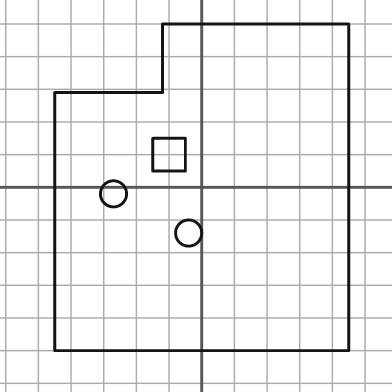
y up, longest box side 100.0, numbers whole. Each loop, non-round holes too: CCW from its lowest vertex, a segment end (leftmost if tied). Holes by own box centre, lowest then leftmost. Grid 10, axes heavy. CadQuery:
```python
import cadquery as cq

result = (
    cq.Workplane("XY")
    .moveTo(-45.0, -50.0)
    .lineTo(45.0, -50.0)
    .lineTo(45.0, 50.0)
    .lineTo(-12.0, 50.0)
    .lineTo(-12.0, 29.0)
    .lineTo(-45.0, 29.0)
    .close()
    .moveTo(-4.0, -14.0)
    .circle(4.0)
    .moveTo(-27.0, -2.0)
    .circle(4.0)
    .moveTo(-15.0, 5.0)
    .lineTo(-5.0, 5.0)
    .lineTo(-5.0, 15.0)
    .lineTo(-15.0, 15.0)
    .close()
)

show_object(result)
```